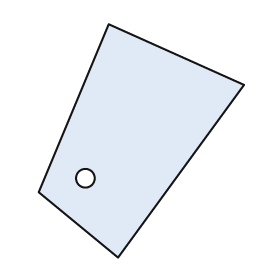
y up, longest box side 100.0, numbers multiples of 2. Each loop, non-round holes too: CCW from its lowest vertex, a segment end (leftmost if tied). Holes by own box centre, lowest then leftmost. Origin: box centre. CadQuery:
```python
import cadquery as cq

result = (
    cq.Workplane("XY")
    .moveTo(-10.0, -50.0)
    .lineTo(44.0, 24.0)
    .lineTo(-14.0, 50.0)
    .lineTo(-44.0, -22.0)
    .close()
    .moveTo(-24.0, -16.0)
    .circle(4.0)
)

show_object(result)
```